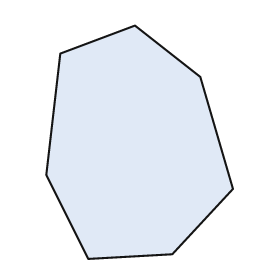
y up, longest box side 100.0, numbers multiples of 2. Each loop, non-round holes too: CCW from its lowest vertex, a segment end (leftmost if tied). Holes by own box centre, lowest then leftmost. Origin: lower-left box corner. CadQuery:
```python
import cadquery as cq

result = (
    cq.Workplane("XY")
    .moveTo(18.0, 0.0)
    .lineTo(54.0, 2.0)
    .lineTo(80.0, 30.0)
    .lineTo(66.0, 78.0)
    .lineTo(38.0, 100.0)
    .lineTo(6.0, 88.0)
    .lineTo(0.0, 36.0)
    .close()
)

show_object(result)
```